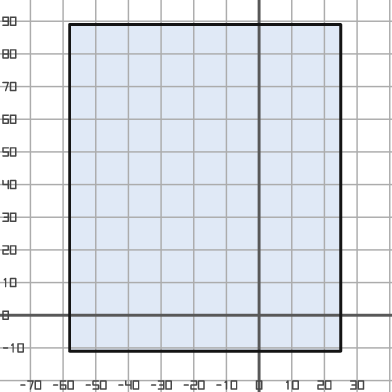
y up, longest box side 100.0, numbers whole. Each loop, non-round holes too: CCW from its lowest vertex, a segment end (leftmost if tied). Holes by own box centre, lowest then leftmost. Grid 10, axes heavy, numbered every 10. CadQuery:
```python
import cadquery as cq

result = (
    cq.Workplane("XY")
    .moveTo(-58.0, -11.0)
    .lineTo(25.0, -11.0)
    .lineTo(25.0, 89.0)
    .lineTo(-58.0, 89.0)
    .close()
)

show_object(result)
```